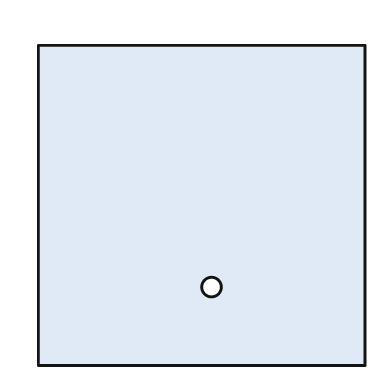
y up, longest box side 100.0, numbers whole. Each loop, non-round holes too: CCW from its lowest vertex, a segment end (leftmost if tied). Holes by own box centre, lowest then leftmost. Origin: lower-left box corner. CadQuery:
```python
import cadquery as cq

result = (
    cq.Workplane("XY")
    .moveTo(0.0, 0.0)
    .lineTo(100.0, 0.0)
    .lineTo(100.0, 98.0)
    .lineTo(0.0, 98.0)
    .close()
    .moveTo(53.0, 24.0)
    .circle(3.0)
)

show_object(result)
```